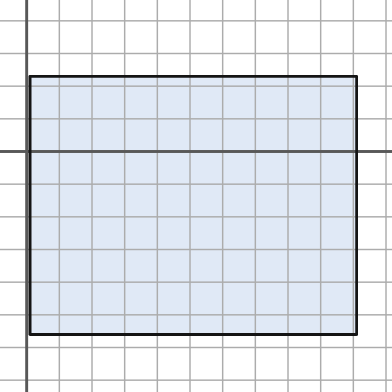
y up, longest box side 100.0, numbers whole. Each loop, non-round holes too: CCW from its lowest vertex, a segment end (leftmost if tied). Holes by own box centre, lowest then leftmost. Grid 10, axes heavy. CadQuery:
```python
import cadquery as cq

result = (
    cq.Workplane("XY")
    .moveTo(1.0, -56.0)
    .lineTo(101.0, -56.0)
    .lineTo(101.0, 23.0)
    .lineTo(1.0, 23.0)
    .close()
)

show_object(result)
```